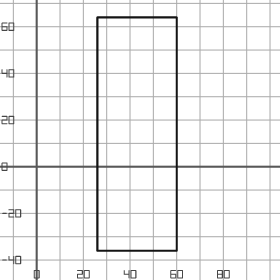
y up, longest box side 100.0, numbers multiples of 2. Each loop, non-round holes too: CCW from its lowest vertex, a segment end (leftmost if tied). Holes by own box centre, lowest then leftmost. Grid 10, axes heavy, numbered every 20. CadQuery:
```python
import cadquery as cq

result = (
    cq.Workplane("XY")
    .moveTo(26.0, -36.0)
    .lineTo(60.0, -36.0)
    .lineTo(60.0, 64.0)
    .lineTo(26.0, 64.0)
    .close()
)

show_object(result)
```